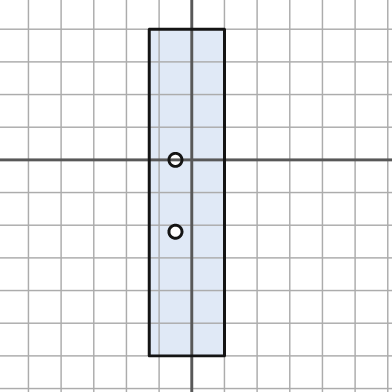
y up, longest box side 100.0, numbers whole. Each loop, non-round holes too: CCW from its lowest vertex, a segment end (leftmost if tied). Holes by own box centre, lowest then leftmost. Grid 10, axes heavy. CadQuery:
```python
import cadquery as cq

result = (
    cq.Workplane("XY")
    .moveTo(-13.0, -60.0)
    .lineTo(10.0, -60.0)
    .lineTo(10.0, 40.0)
    .lineTo(-13.0, 40.0)
    .close()
    .moveTo(-5.0, -22.0)
    .circle(2.0)
    .moveTo(-5.0, 0.0)
    .circle(2.0)
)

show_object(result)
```